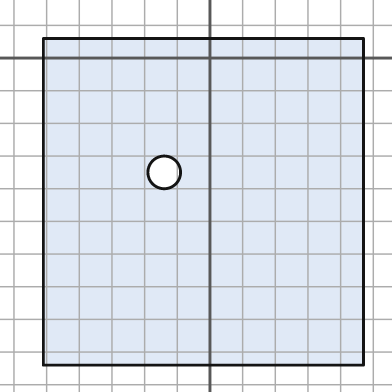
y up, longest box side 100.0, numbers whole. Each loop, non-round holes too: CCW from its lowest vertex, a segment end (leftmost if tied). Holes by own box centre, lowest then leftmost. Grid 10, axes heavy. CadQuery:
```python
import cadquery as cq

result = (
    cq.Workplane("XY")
    .moveTo(-51.0, -94.0)
    .lineTo(47.0, -94.0)
    .lineTo(47.0, 6.0)
    .lineTo(-51.0, 6.0)
    .close()
    .moveTo(-14.0, -35.0)
    .circle(5.0)
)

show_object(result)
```